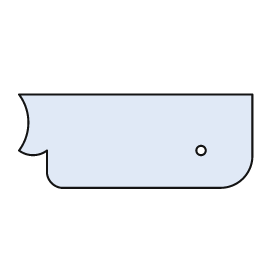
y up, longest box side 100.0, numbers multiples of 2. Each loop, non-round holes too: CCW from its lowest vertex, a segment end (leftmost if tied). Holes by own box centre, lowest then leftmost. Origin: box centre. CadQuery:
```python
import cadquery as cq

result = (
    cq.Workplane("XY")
    .moveTo(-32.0, -20.0)
    .lineTo(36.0, -20.0)
    .threePointArc((46.0, -16.0), (50.0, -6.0))
    .lineTo(50.0, 20.0)
    .lineTo(-50.0, 20.0)
    .threePointArc((-46.0, 8.0), (-50.0, -4.0))
    .threePointArc((-44.0, -6.0), (-38.0, -4.0))
    .lineTo(-38.0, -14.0)
    .threePointArc((-36.0, -18.0), (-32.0, -20.0))
    .close()
    .moveTo(28.0, -4.0)
    .circle(2.0)
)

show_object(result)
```